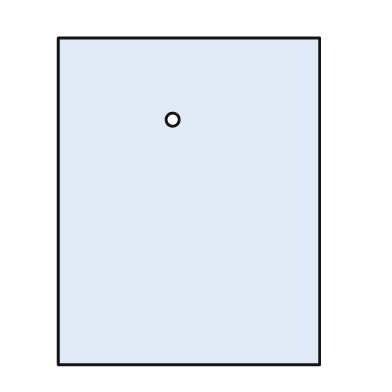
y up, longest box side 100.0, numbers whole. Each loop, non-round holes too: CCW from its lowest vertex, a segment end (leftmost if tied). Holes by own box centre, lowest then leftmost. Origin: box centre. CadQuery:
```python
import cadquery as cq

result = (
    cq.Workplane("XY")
    .moveTo(-40.0, -50.0)
    .lineTo(40.0, -50.0)
    .lineTo(40.0, 50.0)
    .lineTo(-40.0, 50.0)
    .close()
    .moveTo(-5.0, 25.0)
    .circle(2.0)
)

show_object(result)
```